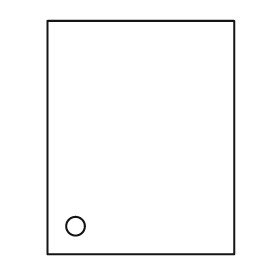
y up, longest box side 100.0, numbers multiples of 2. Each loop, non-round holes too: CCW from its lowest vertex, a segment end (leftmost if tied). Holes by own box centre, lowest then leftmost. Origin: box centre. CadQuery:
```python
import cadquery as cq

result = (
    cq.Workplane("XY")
    .moveTo(-40.0, -50.0)
    .lineTo(40.0, -50.0)
    .lineTo(40.0, 50.0)
    .lineTo(-40.0, 50.0)
    .close()
    .moveTo(-28.0, -38.0)
    .circle(4.0)
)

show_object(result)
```